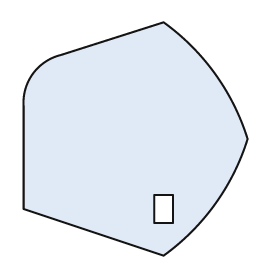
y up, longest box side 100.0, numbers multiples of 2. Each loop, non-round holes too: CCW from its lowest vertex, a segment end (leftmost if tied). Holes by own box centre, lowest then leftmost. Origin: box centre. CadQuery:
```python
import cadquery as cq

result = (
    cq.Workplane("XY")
    .moveTo(12.0, -50.0)
    .threePointArc((34.0, -28.0), (48.0, 0.0))
    .threePointArc((34.0, 28.0), (12.0, 50.0))
    .lineTo(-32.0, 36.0)
    .threePointArc((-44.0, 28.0), (-48.0, 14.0))
    .lineTo(-48.0, -30.0)
    .close()
    .moveTo(8.0, -36.0)
    .lineTo(16.0, -36.0)
    .lineTo(16.0, -24.0)
    .lineTo(8.0, -24.0)
    .close()
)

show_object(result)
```